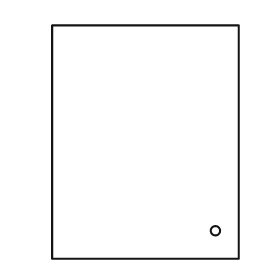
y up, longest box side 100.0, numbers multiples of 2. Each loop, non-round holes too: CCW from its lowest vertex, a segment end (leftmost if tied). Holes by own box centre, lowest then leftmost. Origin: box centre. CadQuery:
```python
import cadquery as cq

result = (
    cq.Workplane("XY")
    .moveTo(-40.0, -50.0)
    .lineTo(40.0, -50.0)
    .lineTo(40.0, 50.0)
    .lineTo(-40.0, 50.0)
    .close()
    .moveTo(30.0, -38.0)
    .circle(2.0)
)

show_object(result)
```